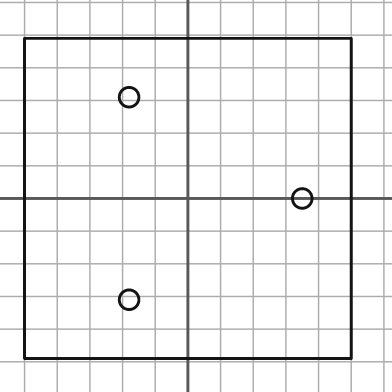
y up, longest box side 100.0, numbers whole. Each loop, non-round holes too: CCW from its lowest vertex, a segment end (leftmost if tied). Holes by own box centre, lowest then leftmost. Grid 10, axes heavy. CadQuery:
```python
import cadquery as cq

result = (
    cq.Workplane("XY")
    .moveTo(-50.0, -49.0)
    .lineTo(50.0, -49.0)
    .lineTo(50.0, 49.0)
    .lineTo(-50.0, 49.0)
    .close()
    .moveTo(-18.0, -31.0)
    .circle(3.0)
    .moveTo(35.0, 0.0)
    .circle(3.0)
    .moveTo(-18.0, 31.0)
    .circle(3.0)
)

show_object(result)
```